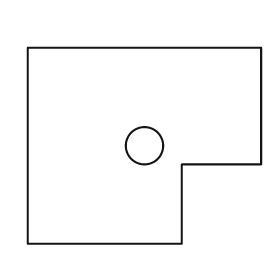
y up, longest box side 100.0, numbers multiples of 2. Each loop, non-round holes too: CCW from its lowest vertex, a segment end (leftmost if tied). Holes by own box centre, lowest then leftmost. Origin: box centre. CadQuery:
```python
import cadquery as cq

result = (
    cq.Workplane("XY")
    .moveTo(-50.0, -42.0)
    .lineTo(16.0, -42.0)
    .lineTo(16.0, -8.0)
    .lineTo(50.0, -8.0)
    .lineTo(50.0, 42.0)
    .lineTo(-50.0, 42.0)
    .close()
    .moveTo(0.0, 0.0)
    .circle(8.0)
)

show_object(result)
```